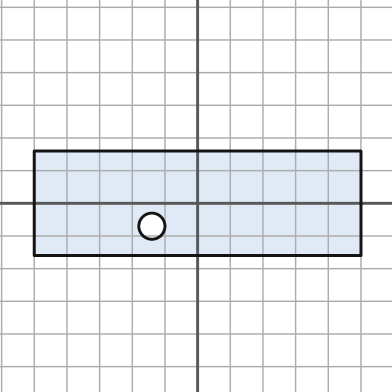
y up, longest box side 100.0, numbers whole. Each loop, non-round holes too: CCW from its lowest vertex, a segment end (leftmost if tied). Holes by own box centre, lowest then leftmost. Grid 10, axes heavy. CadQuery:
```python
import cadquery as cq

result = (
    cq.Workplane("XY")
    .moveTo(-50.0, -16.0)
    .lineTo(50.0, -16.0)
    .lineTo(50.0, 16.0)
    .lineTo(-50.0, 16.0)
    .close()
    .moveTo(-14.0, -7.0)
    .circle(4.0)
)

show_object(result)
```